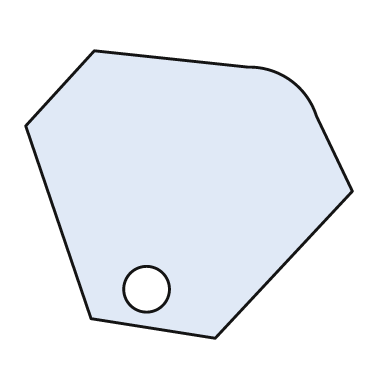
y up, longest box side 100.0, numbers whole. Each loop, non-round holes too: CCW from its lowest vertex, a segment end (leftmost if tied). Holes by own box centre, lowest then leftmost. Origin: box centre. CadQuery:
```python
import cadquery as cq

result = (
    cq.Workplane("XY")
    .moveTo(8.0, -44.0)
    .lineTo(50.0, 1.0)
    .lineTo(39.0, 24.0)
    .threePointArc((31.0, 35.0), (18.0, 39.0))
    .lineTo(-29.0, 44.0)
    .lineTo(-50.0, 21.0)
    .lineTo(-30.0, -38.0)
    .close()
    .moveTo(-13.0, -29.0)
    .circle(7.0)
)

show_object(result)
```